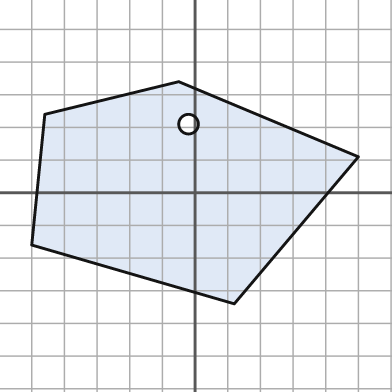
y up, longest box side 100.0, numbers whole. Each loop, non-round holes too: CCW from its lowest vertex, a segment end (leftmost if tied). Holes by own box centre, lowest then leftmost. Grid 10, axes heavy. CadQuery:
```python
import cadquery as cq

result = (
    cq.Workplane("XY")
    .moveTo(12.0, -34.0)
    .lineTo(50.0, 11.0)
    .lineTo(-5.0, 34.0)
    .lineTo(-46.0, 24.0)
    .lineTo(-50.0, -16.0)
    .close()
    .moveTo(-2.0, 21.0)
    .circle(3.0)
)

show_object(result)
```